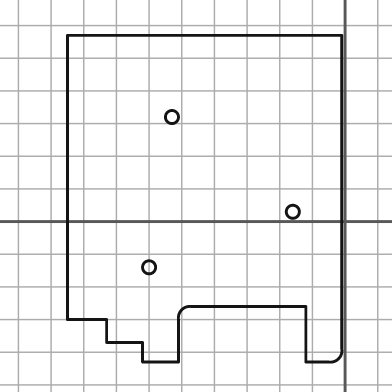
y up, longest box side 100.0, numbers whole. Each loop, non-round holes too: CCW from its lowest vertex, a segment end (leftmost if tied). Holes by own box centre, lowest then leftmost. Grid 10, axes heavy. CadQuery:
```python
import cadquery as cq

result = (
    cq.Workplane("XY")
    .moveTo(-62.0, -43.0)
    .lineTo(-51.0, -43.0)
    .lineTo(-51.0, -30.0)
    .threePointArc((-50.0, -27.0), (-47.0, -26.0))
    .lineTo(-12.0, -26.0)
    .lineTo(-12.0, -43.0)
    .lineTo(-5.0, -43.0)
    .threePointArc((-2.0, -42.0), (-1.0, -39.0))
    .lineTo(-1.0, 57.0)
    .lineTo(-85.0, 57.0)
    .lineTo(-85.0, -30.0)
    .lineTo(-73.0, -30.0)
    .lineTo(-73.0, -37.0)
    .lineTo(-62.0, -37.0)
    .close()
    .moveTo(-60.0, -14.0)
    .circle(2.0)
    .moveTo(-16.0, 3.0)
    .circle(2.0)
    .moveTo(-53.0, 32.0)
    .circle(2.0)
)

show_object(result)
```